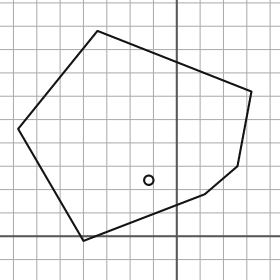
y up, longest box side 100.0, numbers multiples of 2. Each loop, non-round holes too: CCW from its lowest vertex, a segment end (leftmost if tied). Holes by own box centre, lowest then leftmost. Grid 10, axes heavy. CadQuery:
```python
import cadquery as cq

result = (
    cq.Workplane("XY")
    .moveTo(-40.0, -2.0)
    .lineTo(12.0, 18.0)
    .lineTo(26.0, 30.0)
    .lineTo(32.0, 62.0)
    .lineTo(-34.0, 88.0)
    .lineTo(-68.0, 46.0)
    .close()
    .moveTo(-12.0, 24.0)
    .circle(2.0)
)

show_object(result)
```